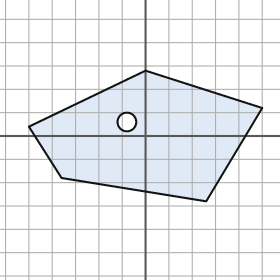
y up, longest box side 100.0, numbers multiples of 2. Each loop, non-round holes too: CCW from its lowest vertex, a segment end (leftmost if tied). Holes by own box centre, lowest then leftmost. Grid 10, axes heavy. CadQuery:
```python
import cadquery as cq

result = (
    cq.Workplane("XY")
    .moveTo(26.0, -28.0)
    .lineTo(50.0, 12.0)
    .lineTo(0.0, 28.0)
    .lineTo(-50.0, 4.0)
    .lineTo(-36.0, -18.0)
    .close()
    .moveTo(-8.0, 6.0)
    .circle(4.0)
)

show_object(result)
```